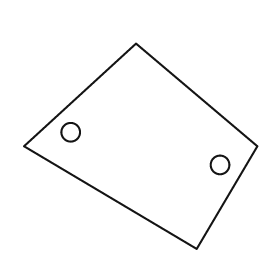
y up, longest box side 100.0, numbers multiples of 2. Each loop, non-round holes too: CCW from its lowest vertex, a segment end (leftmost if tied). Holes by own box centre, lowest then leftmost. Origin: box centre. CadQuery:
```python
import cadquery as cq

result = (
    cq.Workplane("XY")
    .moveTo(24.0, -44.0)
    .lineTo(50.0, 0.0)
    .lineTo(-2.0, 44.0)
    .lineTo(-50.0, 0.0)
    .close()
    .moveTo(34.0, -8.0)
    .circle(4.0)
    .moveTo(-30.0, 6.0)
    .circle(4.0)
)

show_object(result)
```